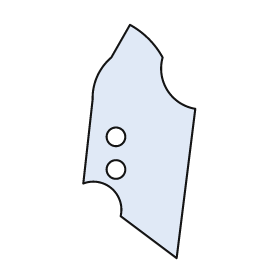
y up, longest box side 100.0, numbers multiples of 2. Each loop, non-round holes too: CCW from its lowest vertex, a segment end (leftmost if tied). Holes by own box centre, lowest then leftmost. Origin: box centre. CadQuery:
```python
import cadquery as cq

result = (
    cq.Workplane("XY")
    .moveTo(16.0, -50.0)
    .lineTo(24.0, 14.0)
    .threePointArc((12.0, 22.0), (10.0, 36.0))
    .threePointArc((4.0, 44.0), (-4.0, 50.0))
    .lineTo(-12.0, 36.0)
    .threePointArc((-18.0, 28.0), (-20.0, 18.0))
    .lineTo(-24.0, -18.0)
    .threePointArc((-12.0, -20.0), (-8.0, -32.0))
    .close()
    .moveTo(-10.0, -12.0)
    .circle(4.0)
    .moveTo(-10.0, 2.0)
    .circle(4.0)
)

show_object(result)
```